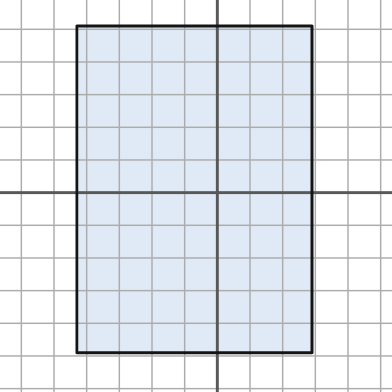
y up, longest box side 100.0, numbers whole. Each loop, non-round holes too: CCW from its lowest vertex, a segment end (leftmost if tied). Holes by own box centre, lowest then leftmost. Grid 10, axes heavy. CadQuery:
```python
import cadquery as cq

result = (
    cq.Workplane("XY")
    .moveTo(-43.0, -49.0)
    .lineTo(29.0, -49.0)
    .lineTo(29.0, 51.0)
    .lineTo(-43.0, 51.0)
    .close()
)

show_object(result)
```